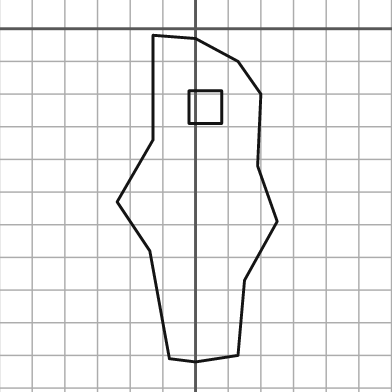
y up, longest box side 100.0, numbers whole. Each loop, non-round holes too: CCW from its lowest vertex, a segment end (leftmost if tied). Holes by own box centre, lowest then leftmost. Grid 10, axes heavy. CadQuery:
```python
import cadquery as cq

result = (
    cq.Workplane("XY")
    .moveTo(0.0, -102.0)
    .lineTo(13.0, -100.0)
    .lineTo(15.0, -77.0)
    .lineTo(25.0, -59.0)
    .lineTo(19.0, -42.0)
    .lineTo(20.0, -20.0)
    .lineTo(13.0, -10.0)
    .lineTo(0.0, -3.0)
    .lineTo(-13.0, -2.0)
    .lineTo(-13.0, -34.0)
    .lineTo(-24.0, -53.0)
    .lineTo(-14.0, -68.0)
    .lineTo(-8.0, -101.0)
    .close()
    .moveTo(-2.0, -29.0)
    .lineTo(8.0, -29.0)
    .lineTo(8.0, -19.0)
    .lineTo(-2.0, -19.0)
    .close()
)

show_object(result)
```